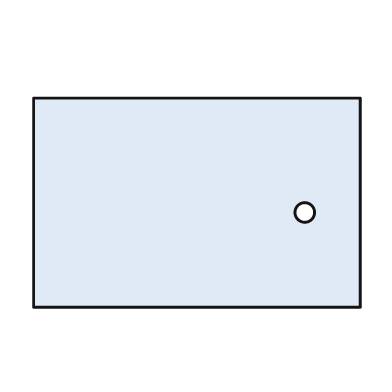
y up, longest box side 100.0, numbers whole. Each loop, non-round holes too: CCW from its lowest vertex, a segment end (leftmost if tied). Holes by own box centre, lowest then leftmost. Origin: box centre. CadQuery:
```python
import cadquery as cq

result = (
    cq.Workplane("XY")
    .moveTo(-50.0, -32.0)
    .lineTo(50.0, -32.0)
    .lineTo(50.0, 32.0)
    .lineTo(-50.0, 32.0)
    .close()
    .moveTo(33.0, -3.0)
    .circle(3.0)
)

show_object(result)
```